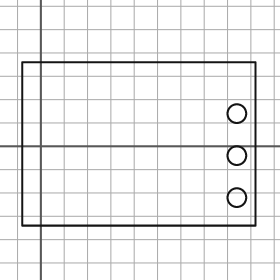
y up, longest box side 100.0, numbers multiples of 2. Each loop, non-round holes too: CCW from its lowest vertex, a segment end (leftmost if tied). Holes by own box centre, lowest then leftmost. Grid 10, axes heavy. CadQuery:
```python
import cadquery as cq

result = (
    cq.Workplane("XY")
    .moveTo(-8.0, -34.0)
    .lineTo(92.0, -34.0)
    .lineTo(92.0, 36.0)
    .lineTo(-8.0, 36.0)
    .close()
    .moveTo(84.0, -22.0)
    .circle(4.0)
    .moveTo(84.0, -4.0)
    .circle(4.0)
    .moveTo(84.0, 14.0)
    .circle(4.0)
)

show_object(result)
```